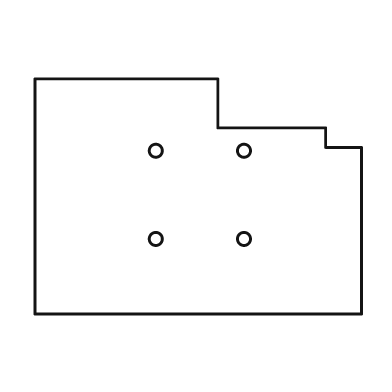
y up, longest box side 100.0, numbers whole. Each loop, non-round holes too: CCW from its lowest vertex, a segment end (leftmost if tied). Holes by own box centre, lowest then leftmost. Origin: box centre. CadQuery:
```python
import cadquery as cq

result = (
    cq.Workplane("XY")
    .moveTo(-50.0, -36.0)
    .lineTo(50.0, -36.0)
    .lineTo(50.0, 15.0)
    .lineTo(39.0, 15.0)
    .lineTo(39.0, 21.0)
    .lineTo(6.0, 21.0)
    .lineTo(6.0, 36.0)
    .lineTo(-50.0, 36.0)
    .close()
    .moveTo(-13.0, -13.0)
    .circle(2.0)
    .moveTo(14.0, -13.0)
    .circle(2.0)
    .moveTo(-13.0, 14.0)
    .circle(2.0)
    .moveTo(14.0, 14.0)
    .circle(2.0)
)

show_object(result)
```